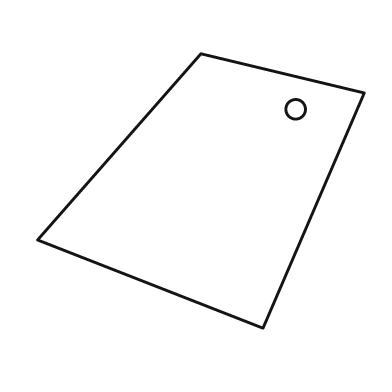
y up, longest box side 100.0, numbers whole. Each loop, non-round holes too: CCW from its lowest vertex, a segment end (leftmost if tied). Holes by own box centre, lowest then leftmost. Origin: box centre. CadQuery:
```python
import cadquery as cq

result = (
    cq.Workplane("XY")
    .moveTo(19.0, -42.0)
    .lineTo(50.0, 30.0)
    .lineTo(0.0, 42.0)
    .lineTo(-50.0, -15.0)
    .close()
    .moveTo(29.0, 25.0)
    .circle(3.0)
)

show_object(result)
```